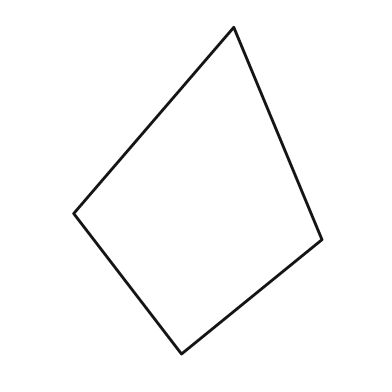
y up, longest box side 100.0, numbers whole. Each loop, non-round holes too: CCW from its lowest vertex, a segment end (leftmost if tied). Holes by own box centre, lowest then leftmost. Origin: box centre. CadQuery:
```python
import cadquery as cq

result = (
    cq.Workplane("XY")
    .moveTo(-5.0, -50.0)
    .lineTo(38.0, -15.0)
    .lineTo(11.0, 50.0)
    .lineTo(-38.0, -7.0)
    .close()
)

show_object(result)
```